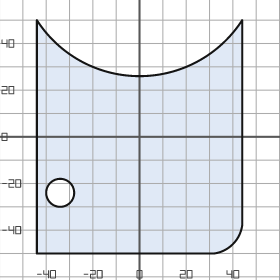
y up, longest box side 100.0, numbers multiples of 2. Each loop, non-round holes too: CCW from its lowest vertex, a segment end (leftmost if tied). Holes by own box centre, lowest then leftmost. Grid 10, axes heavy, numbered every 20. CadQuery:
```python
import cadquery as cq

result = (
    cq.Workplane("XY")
    .moveTo(-44.0, -50.0)
    .lineTo(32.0, -50.0)
    .threePointArc((40.0, -46.0), (44.0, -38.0))
    .lineTo(44.0, 50.0)
    .threePointArc((0.0, 26.0), (-44.0, 50.0))
    .close()
    .moveTo(-34.0, -24.0)
    .circle(6.0)
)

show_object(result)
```